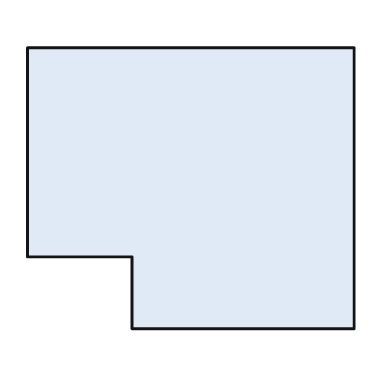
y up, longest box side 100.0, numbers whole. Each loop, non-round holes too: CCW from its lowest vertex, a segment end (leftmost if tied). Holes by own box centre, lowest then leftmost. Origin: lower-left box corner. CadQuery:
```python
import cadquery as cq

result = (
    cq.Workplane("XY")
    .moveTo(32.0, 0.0)
    .lineTo(100.0, 0.0)
    .lineTo(100.0, 86.0)
    .lineTo(0.0, 86.0)
    .lineTo(0.0, 22.0)
    .lineTo(32.0, 22.0)
    .close()
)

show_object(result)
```